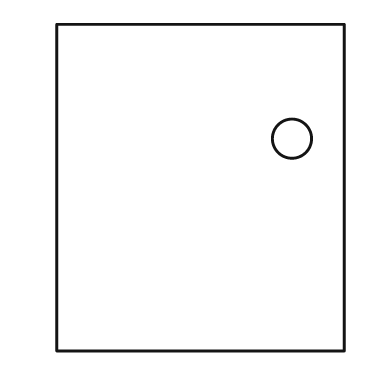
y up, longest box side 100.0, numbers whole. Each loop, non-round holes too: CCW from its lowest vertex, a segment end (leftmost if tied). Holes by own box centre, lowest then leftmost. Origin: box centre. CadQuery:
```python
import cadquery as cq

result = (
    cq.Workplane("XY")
    .moveTo(-44.0, -50.0)
    .lineTo(44.0, -50.0)
    .lineTo(44.0, 50.0)
    .lineTo(-44.0, 50.0)
    .close()
    .moveTo(28.0, 15.0)
    .circle(6.0)
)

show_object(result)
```